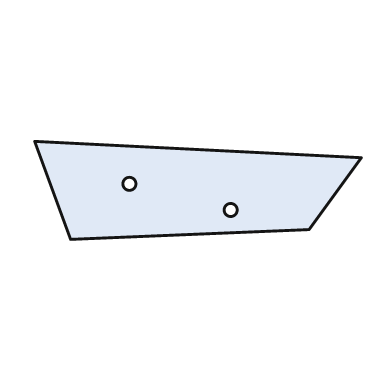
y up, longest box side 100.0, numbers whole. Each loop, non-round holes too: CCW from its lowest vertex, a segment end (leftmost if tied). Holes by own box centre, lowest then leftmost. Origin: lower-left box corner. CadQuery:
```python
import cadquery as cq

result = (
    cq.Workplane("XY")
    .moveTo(11.0, 0.0)
    .lineTo(84.0, 3.0)
    .lineTo(100.0, 25.0)
    .lineTo(0.0, 30.0)
    .close()
    .moveTo(60.0, 9.0)
    .circle(2.0)
    .moveTo(29.0, 17.0)
    .circle(2.0)
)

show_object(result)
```